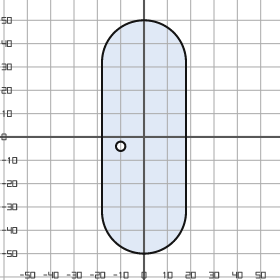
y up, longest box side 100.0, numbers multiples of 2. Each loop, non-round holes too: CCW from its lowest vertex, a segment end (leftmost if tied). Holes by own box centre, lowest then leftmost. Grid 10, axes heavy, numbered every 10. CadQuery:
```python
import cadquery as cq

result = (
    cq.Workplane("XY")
    .moveTo(-18.0, -32.0)
    .threePointArc((0.0, -50.0), (18.0, -32.0))
    .lineTo(18.0, 32.0)
    .threePointArc((0.0, 50.0), (-18.0, 32.0))
    .close()
    .moveTo(-10.0, -4.0)
    .circle(2.0)
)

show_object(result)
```